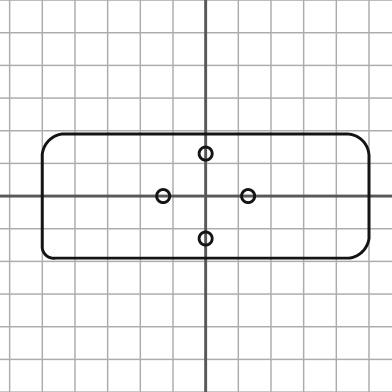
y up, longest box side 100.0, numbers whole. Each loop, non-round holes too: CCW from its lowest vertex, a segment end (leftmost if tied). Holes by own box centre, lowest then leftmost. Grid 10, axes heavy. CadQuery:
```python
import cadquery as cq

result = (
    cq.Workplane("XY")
    .moveTo(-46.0, -19.0)
    .lineTo(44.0, -19.0)
    .threePointArc((48.0, -17.0), (50.0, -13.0))
    .lineTo(50.0, 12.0)
    .threePointArc((48.0, 17.0), (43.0, 19.0))
    .lineTo(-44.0, 19.0)
    .threePointArc((-48.0, 17.0), (-50.0, 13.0))
    .lineTo(-50.0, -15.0)
    .threePointArc((-49.0, -18.0), (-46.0, -19.0))
    .close()
    .moveTo(0.0, -13.0)
    .circle(2.0)
    .moveTo(-13.0, 0.0)
    .circle(2.0)
    .moveTo(13.0, 0.0)
    .circle(2.0)
    .moveTo(0.0, 13.0)
    .circle(2.0)
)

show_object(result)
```